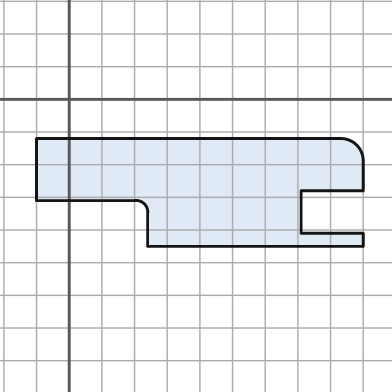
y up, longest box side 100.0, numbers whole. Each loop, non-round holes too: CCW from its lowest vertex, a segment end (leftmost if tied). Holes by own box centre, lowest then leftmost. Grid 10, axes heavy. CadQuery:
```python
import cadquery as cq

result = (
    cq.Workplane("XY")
    .moveTo(24.0, -45.0)
    .lineTo(90.0, -45.0)
    .lineTo(90.0, -41.0)
    .lineTo(71.0, -41.0)
    .lineTo(71.0, -28.0)
    .lineTo(90.0, -28.0)
    .lineTo(90.0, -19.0)
    .threePointArc((88.0, -14.0), (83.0, -12.0))
    .lineTo(-10.0, -12.0)
    .lineTo(-10.0, -31.0)
    .lineTo(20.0, -31.0)
    .threePointArc((23.0, -32.0), (24.0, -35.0))
    .close()
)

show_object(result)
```